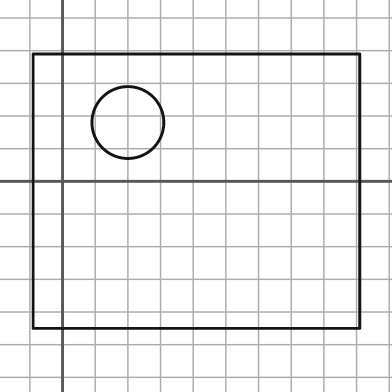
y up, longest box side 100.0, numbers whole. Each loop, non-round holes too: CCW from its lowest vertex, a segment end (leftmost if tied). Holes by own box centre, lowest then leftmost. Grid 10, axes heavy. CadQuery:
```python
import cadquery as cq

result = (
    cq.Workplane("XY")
    .moveTo(-9.0, -45.0)
    .lineTo(91.0, -45.0)
    .lineTo(91.0, 39.0)
    .lineTo(-9.0, 39.0)
    .close()
    .moveTo(20.0, 18.0)
    .circle(11.0)
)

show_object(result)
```